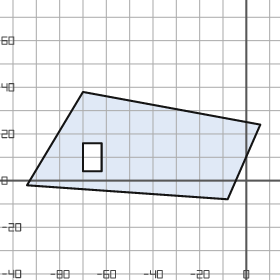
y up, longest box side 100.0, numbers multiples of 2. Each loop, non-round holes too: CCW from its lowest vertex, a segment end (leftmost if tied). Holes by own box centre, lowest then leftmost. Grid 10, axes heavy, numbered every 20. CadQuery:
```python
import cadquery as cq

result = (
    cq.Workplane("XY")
    .moveTo(-8.0, -8.0)
    .lineTo(6.0, 24.0)
    .lineTo(-70.0, 38.0)
    .lineTo(-94.0, -2.0)
    .close()
    .moveTo(-70.0, 4.0)
    .lineTo(-62.0, 4.0)
    .lineTo(-62.0, 16.0)
    .lineTo(-70.0, 16.0)
    .close()
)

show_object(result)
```